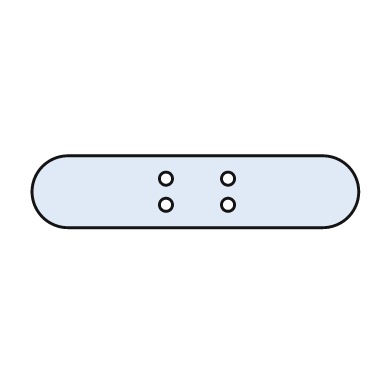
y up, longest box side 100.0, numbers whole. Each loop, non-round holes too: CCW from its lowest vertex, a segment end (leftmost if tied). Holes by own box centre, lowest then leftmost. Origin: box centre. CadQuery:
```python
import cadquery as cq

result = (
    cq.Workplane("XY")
    .moveTo(-39.0, -11.0)
    .lineTo(39.0, -11.0)
    .threePointArc((50.0, 0.0), (39.0, 11.0))
    .lineTo(-39.0, 11.0)
    .threePointArc((-50.0, 0.0), (-39.0, -11.0))
    .close()
    .moveTo(-9.0, -4.0)
    .circle(2.0)
    .moveTo(10.0, -4.0)
    .circle(2.0)
    .moveTo(-9.0, 4.0)
    .circle(2.0)
    .moveTo(10.0, 4.0)
    .circle(2.0)
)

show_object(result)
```